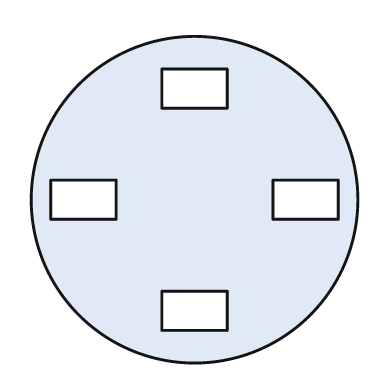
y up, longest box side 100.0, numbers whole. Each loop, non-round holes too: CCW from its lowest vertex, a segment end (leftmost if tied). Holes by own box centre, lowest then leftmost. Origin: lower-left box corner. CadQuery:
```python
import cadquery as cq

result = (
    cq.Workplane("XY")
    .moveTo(50.0, 50.0)
    .circle(50.0)
    .moveTo(40.0, 10.0)
    .lineTo(60.0, 10.0)
    .lineTo(60.0, 22.0)
    .lineTo(40.0, 22.0)
    .close()
    .moveTo(6.0, 44.0)
    .lineTo(26.0, 44.0)
    .lineTo(26.0, 56.0)
    .lineTo(6.0, 56.0)
    .close()
    .moveTo(74.0, 44.0)
    .lineTo(94.0, 44.0)
    .lineTo(94.0, 56.0)
    .lineTo(74.0, 56.0)
    .close()
    .moveTo(40.0, 78.0)
    .lineTo(60.0, 78.0)
    .lineTo(60.0, 90.0)
    .lineTo(40.0, 90.0)
    .close()
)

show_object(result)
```